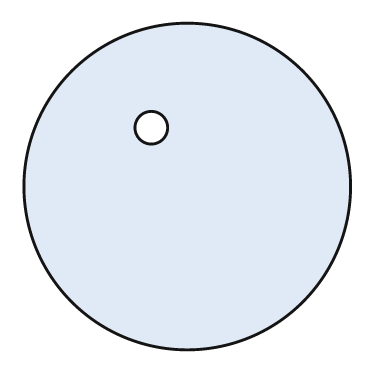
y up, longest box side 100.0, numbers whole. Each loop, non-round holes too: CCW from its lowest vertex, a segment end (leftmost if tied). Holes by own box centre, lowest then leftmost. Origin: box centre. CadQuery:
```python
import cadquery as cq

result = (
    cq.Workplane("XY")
    .moveTo(0.0, 0.0)
    .circle(50.0)
    .moveTo(-11.0, 18.0)
    .circle(5.0)
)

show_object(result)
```